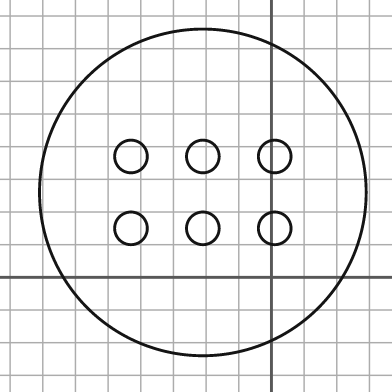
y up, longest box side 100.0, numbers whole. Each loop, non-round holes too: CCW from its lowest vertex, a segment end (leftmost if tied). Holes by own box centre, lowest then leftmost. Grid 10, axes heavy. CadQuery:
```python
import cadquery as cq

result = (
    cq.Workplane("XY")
    .moveTo(-21.0, 26.0)
    .circle(50.0)
    .moveTo(-43.0, 15.0)
    .circle(5.0)
    .moveTo(-21.0, 15.0)
    .circle(5.0)
    .moveTo(1.0, 15.0)
    .circle(5.0)
    .moveTo(-43.0, 37.0)
    .circle(5.0)
    .moveTo(-21.0, 37.0)
    .circle(5.0)
    .moveTo(1.0, 37.0)
    .circle(5.0)
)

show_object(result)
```